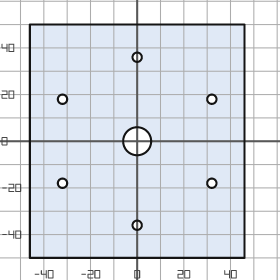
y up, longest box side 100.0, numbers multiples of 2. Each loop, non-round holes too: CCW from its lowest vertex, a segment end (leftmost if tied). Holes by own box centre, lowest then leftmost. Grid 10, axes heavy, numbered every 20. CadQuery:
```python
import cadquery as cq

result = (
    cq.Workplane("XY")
    .moveTo(-46.0, -50.0)
    .lineTo(46.0, -50.0)
    .lineTo(46.0, 50.0)
    .lineTo(-46.0, 50.0)
    .close()
    .moveTo(0.0, -36.0)
    .circle(2.0)
    .moveTo(-32.0, -18.0)
    .circle(2.0)
    .moveTo(32.0, -18.0)
    .circle(2.0)
    .moveTo(0.0, 0.0)
    .circle(6.0)
    .moveTo(-32.0, 18.0)
    .circle(2.0)
    .moveTo(32.0, 18.0)
    .circle(2.0)
    .moveTo(0.0, 36.0)
    .circle(2.0)
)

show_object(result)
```